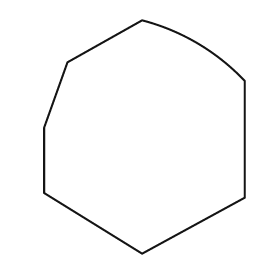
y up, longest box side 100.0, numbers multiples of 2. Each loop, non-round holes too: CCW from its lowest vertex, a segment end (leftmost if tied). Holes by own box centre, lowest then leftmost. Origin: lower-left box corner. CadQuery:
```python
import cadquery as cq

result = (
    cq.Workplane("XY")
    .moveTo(42.0, 0.0)
    .lineTo(86.0, 24.0)
    .lineTo(86.0, 74.0)
    .threePointArc((66.0, 90.0), (42.0, 100.0))
    .lineTo(10.0, 82.0)
    .lineTo(0.0, 54.0)
    .lineTo(0.0, 26.0)
    .close()
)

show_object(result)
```